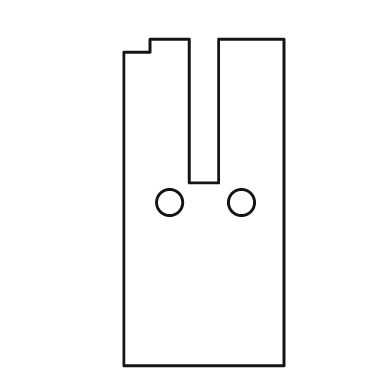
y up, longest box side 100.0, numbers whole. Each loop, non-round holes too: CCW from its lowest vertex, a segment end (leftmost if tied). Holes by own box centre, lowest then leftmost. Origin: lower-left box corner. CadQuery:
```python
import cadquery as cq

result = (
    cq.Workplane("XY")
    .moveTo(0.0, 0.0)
    .lineTo(49.0, 0.0)
    .lineTo(49.0, 100.0)
    .lineTo(29.0, 100.0)
    .lineTo(29.0, 56.0)
    .lineTo(20.0, 56.0)
    .lineTo(20.0, 100.0)
    .lineTo(8.0, 100.0)
    .lineTo(8.0, 96.0)
    .lineTo(0.0, 96.0)
    .close()
    .moveTo(14.0, 50.0)
    .circle(4.0)
    .moveTo(36.0, 50.0)
    .circle(4.0)
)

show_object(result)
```